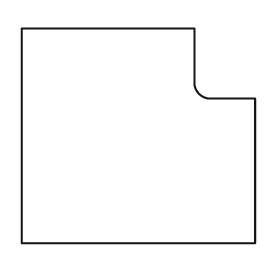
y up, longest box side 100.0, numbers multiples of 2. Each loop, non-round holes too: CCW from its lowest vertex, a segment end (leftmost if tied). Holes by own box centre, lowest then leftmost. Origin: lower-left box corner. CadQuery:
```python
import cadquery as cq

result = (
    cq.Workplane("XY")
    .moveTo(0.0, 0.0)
    .lineTo(100.0, 0.0)
    .lineTo(100.0, 62.0)
    .lineTo(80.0, 62.0)
    .threePointArc((76.0, 64.0), (74.0, 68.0))
    .lineTo(74.0, 92.0)
    .lineTo(0.0, 92.0)
    .close()
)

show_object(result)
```